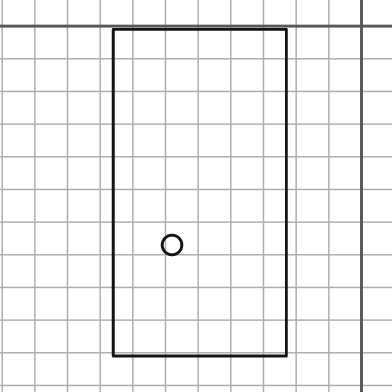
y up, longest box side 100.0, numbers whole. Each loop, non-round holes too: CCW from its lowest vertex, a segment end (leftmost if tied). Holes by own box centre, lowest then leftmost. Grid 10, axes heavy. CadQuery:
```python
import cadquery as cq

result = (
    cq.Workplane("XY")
    .moveTo(-76.0, -101.0)
    .lineTo(-23.0, -101.0)
    .lineTo(-23.0, -1.0)
    .lineTo(-76.0, -1.0)
    .close()
    .moveTo(-58.0, -67.0)
    .circle(3.0)
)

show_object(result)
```